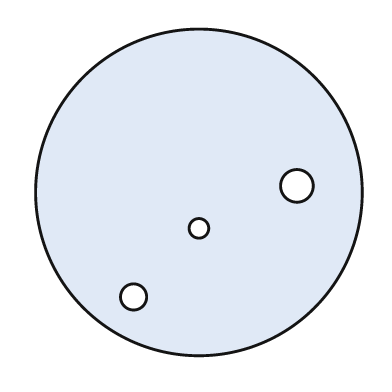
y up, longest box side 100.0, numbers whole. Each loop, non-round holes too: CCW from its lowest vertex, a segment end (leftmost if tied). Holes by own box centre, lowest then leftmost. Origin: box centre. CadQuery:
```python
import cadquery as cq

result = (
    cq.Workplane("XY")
    .moveTo(0.0, 0.0)
    .circle(50.0)
    .moveTo(-20.0, -32.0)
    .circle(4.0)
    .moveTo(0.0, -11.0)
    .circle(3.0)
    .moveTo(30.0, 2.0)
    .circle(5.0)
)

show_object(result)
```